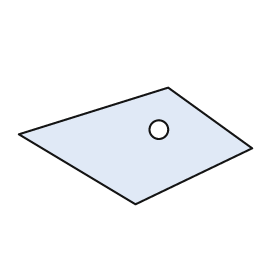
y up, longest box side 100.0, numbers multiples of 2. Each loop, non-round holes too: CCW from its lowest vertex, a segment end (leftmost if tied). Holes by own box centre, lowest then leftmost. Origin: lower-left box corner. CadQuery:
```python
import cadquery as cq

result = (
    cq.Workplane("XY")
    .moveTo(50.0, 0.0)
    .lineTo(100.0, 24.0)
    .lineTo(64.0, 50.0)
    .lineTo(0.0, 30.0)
    .close()
    .moveTo(60.0, 32.0)
    .circle(4.0)
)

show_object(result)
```